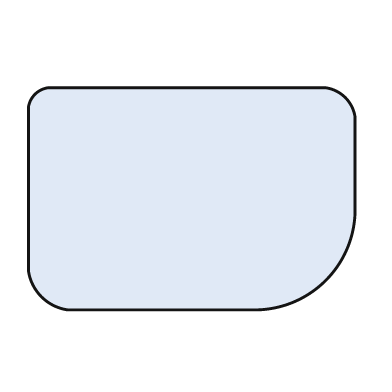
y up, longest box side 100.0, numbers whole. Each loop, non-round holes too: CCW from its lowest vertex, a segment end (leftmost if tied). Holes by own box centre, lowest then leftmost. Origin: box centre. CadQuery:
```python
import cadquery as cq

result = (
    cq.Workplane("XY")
    .moveTo(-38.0, -34.0)
    .lineTo(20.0, -34.0)
    .threePointArc((41.0, -25.0), (50.0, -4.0))
    .lineTo(50.0, 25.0)
    .threePointArc((47.0, 31.0), (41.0, 34.0))
    .lineTo(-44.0, 34.0)
    .threePointArc((-48.0, 32.0), (-50.0, 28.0))
    .lineTo(-50.0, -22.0)
    .threePointArc((-46.0, -30.0), (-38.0, -34.0))
    .close()
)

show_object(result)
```